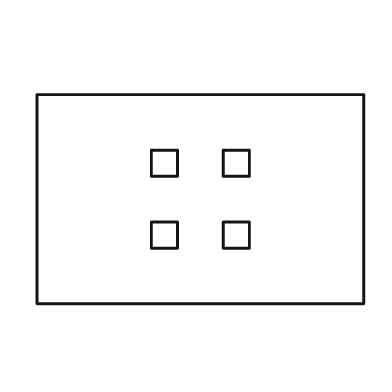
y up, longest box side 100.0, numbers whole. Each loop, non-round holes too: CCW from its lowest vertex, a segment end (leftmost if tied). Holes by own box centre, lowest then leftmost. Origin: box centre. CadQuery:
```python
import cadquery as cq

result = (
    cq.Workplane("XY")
    .moveTo(-50.0, -32.0)
    .lineTo(50.0, -32.0)
    .lineTo(50.0, 32.0)
    .lineTo(-50.0, 32.0)
    .close()
    .moveTo(-15.0, -15.0)
    .lineTo(-7.0, -15.0)
    .lineTo(-7.0, -7.0)
    .lineTo(-15.0, -7.0)
    .close()
    .moveTo(7.0, -15.0)
    .lineTo(15.0, -15.0)
    .lineTo(15.0, -7.0)
    .lineTo(7.0, -7.0)
    .close()
    .moveTo(-15.0, 7.0)
    .lineTo(-7.0, 7.0)
    .lineTo(-7.0, 15.0)
    .lineTo(-15.0, 15.0)
    .close()
    .moveTo(7.0, 7.0)
    .lineTo(15.0, 7.0)
    .lineTo(15.0, 15.0)
    .lineTo(7.0, 15.0)
    .close()
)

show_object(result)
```